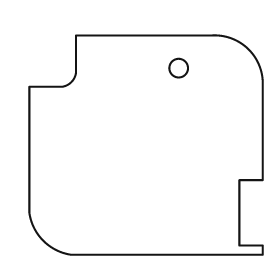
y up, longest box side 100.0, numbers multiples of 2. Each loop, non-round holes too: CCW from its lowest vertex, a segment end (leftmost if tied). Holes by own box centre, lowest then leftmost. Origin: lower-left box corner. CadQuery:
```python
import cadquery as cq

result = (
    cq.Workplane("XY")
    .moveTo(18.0, 0.0)
    .lineTo(100.0, 0.0)
    .lineTo(100.0, 4.0)
    .lineTo(90.0, 4.0)
    .lineTo(90.0, 32.0)
    .lineTo(100.0, 32.0)
    .lineTo(100.0, 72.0)
    .threePointArc((94.0, 88.0), (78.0, 94.0))
    .lineTo(20.0, 94.0)
    .lineTo(20.0, 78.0)
    .threePointArc((18.0, 74.0), (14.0, 72.0))
    .lineTo(0.0, 72.0)
    .lineTo(0.0, 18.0)
    .threePointArc((6.0, 6.0), (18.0, 0.0))
    .close()
    .moveTo(64.0, 80.0)
    .circle(4.0)
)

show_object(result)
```